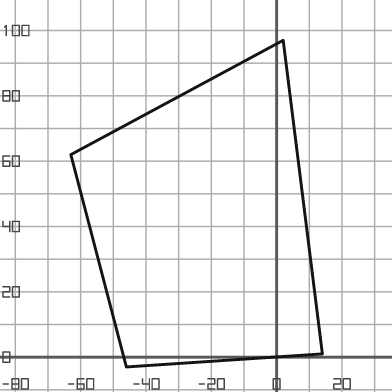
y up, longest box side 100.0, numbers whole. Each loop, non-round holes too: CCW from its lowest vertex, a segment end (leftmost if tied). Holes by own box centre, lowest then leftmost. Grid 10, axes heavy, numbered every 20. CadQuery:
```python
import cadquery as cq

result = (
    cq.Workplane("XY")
    .moveTo(-46.0, -3.0)
    .lineTo(14.0, 1.0)
    .lineTo(2.0, 97.0)
    .lineTo(-63.0, 62.0)
    .close()
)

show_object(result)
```